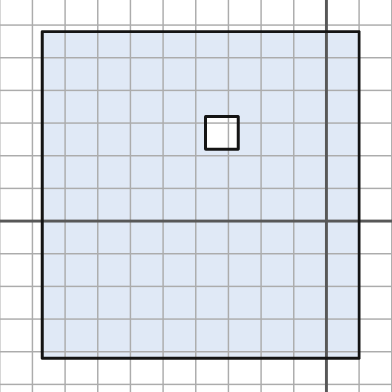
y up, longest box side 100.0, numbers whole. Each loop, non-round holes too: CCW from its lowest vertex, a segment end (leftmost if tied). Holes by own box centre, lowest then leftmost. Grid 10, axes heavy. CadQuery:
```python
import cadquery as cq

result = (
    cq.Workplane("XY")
    .moveTo(-87.0, -42.0)
    .lineTo(10.0, -42.0)
    .lineTo(10.0, 58.0)
    .lineTo(-87.0, 58.0)
    .close()
    .moveTo(-37.0, 22.0)
    .lineTo(-27.0, 22.0)
    .lineTo(-27.0, 32.0)
    .lineTo(-37.0, 32.0)
    .close()
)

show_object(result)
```